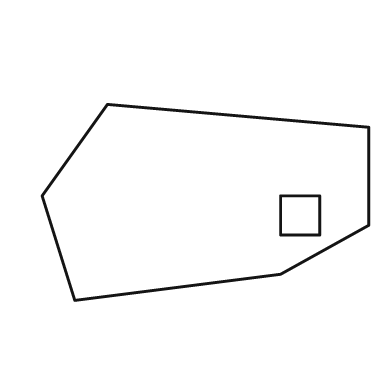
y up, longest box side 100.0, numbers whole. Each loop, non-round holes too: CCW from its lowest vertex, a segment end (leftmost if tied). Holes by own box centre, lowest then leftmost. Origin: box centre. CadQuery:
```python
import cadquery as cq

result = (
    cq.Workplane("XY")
    .moveTo(-40.0, -30.0)
    .lineTo(23.0, -22.0)
    .lineTo(50.0, -7.0)
    .lineTo(50.0, 23.0)
    .lineTo(-30.0, 30.0)
    .lineTo(-50.0, 2.0)
    .close()
    .moveTo(23.0, -10.0)
    .lineTo(35.0, -10.0)
    .lineTo(35.0, 2.0)
    .lineTo(23.0, 2.0)
    .close()
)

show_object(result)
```